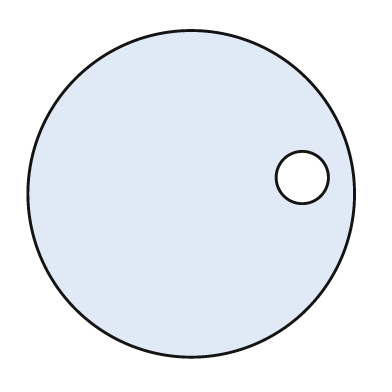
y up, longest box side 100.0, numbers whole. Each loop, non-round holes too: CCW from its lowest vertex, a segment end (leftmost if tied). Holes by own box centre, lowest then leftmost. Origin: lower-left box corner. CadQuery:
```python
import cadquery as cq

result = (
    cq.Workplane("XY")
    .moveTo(50.0, 50.0)
    .circle(50.0)
    .moveTo(84.0, 55.0)
    .circle(8.0)
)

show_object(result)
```